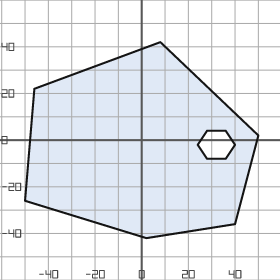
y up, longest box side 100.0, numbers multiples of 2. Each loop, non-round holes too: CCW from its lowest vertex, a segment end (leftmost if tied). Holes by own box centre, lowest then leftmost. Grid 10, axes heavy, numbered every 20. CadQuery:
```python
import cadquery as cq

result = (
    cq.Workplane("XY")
    .moveTo(2.0, -42.0)
    .lineTo(40.0, -36.0)
    .lineTo(50.0, 2.0)
    .lineTo(8.0, 42.0)
    .lineTo(-46.0, 22.0)
    .lineTo(-50.0, -26.0)
    .close()
    .moveTo(28.0, -8.0)
    .lineTo(36.0, -8.0)
    .lineTo(40.0, -2.0)
    .lineTo(36.0, 4.0)
    .lineTo(28.0, 4.0)
    .lineTo(24.0, -2.0)
    .close()
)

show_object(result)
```